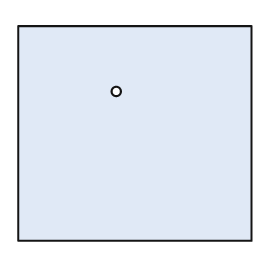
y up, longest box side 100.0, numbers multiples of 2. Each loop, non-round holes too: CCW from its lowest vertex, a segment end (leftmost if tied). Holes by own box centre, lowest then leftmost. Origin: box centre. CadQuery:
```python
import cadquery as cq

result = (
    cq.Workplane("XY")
    .moveTo(-50.0, -46.0)
    .lineTo(50.0, -46.0)
    .lineTo(50.0, 46.0)
    .lineTo(-50.0, 46.0)
    .close()
    .moveTo(-8.0, 18.0)
    .circle(2.0)
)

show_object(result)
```